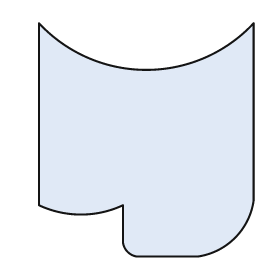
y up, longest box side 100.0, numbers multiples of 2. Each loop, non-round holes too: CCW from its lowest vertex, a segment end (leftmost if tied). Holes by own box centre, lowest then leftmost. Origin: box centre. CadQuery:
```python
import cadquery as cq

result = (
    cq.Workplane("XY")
    .moveTo(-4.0, -50.0)
    .lineTo(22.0, -50.0)
    .threePointArc((38.0, -42.0), (46.0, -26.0))
    .lineTo(46.0, 50.0)
    .threePointArc((0.0, 30.0), (-46.0, 50.0))
    .lineTo(-46.0, -28.0)
    .threePointArc((-28.0, -32.0), (-10.0, -28.0))
    .lineTo(-10.0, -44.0)
    .threePointArc((-8.0, -48.0), (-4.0, -50.0))
    .close()
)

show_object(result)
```